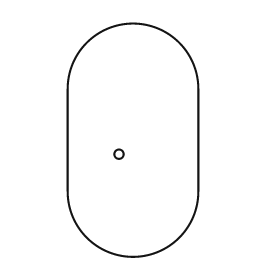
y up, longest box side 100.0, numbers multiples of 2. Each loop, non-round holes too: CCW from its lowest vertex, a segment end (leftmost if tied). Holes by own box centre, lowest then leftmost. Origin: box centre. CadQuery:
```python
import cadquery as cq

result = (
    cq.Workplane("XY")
    .moveTo(-28.0, -22.0)
    .threePointArc((0.0, -50.0), (28.0, -22.0))
    .lineTo(28.0, 22.0)
    .threePointArc((0.0, 50.0), (-28.0, 22.0))
    .close()
    .moveTo(-6.0, -6.0)
    .circle(2.0)
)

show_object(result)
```